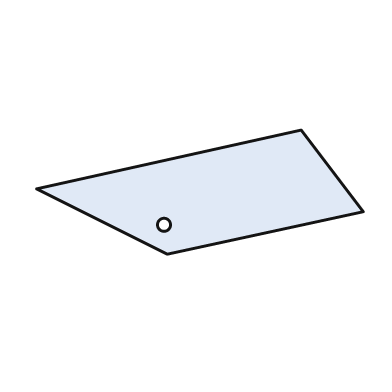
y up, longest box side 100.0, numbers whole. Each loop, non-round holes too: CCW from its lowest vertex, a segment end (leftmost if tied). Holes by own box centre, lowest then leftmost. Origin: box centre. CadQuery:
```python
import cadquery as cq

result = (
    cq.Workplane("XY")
    .moveTo(-10.0, -19.0)
    .lineTo(50.0, -6.0)
    .lineTo(31.0, 19.0)
    .lineTo(-50.0, 1.0)
    .close()
    .moveTo(-11.0, -10.0)
    .circle(2.0)
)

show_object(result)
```